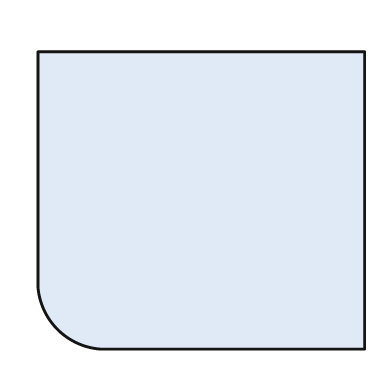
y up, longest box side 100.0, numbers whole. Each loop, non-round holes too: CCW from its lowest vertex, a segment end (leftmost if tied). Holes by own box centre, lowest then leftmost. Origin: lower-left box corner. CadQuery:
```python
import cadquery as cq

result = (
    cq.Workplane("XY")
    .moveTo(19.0, 0.0)
    .lineTo(100.0, 0.0)
    .lineTo(100.0, 91.0)
    .lineTo(0.0, 91.0)
    .lineTo(0.0, 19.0)
    .threePointArc((6.0, 6.0), (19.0, 0.0))
    .close()
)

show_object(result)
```